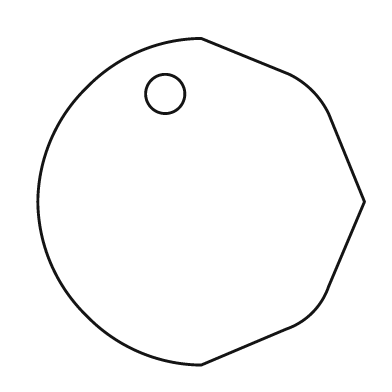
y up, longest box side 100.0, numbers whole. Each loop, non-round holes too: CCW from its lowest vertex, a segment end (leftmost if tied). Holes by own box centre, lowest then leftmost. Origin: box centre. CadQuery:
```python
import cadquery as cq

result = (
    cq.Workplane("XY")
    .moveTo(0.0, -50.0)
    .lineTo(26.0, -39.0)
    .threePointArc((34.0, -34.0), (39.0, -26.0))
    .lineTo(50.0, 0.0)
    .lineTo(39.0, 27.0)
    .threePointArc((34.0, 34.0), (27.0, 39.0))
    .lineTo(0.0, 50.0)
    .threePointArc((-19.0, 46.0), (-35.0, 35.0))
    .threePointArc((-46.0, 19.0), (-50.0, 0.0))
    .threePointArc((-46.0, -19.0), (-35.0, -35.0))
    .threePointArc((-19.0, -46.0), (0.0, -50.0))
    .close()
    .moveTo(-11.0, 33.0)
    .circle(6.0)
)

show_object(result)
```